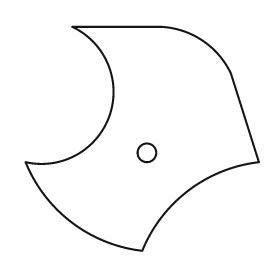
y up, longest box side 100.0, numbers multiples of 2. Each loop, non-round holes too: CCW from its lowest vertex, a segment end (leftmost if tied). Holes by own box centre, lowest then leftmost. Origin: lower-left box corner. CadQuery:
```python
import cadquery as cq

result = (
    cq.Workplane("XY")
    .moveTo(50.0, 0.0)
    .threePointArc((70.0, 26.0), (100.0, 38.0))
    .lineTo(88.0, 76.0)
    .threePointArc((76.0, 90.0), (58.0, 96.0))
    .lineTo(20.0, 96.0)
    .threePointArc((36.0, 58.0), (0.0, 38.0))
    .threePointArc((20.0, 12.0), (50.0, 0.0))
    .close()
    .moveTo(52.0, 42.0)
    .circle(4.0)
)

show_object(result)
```